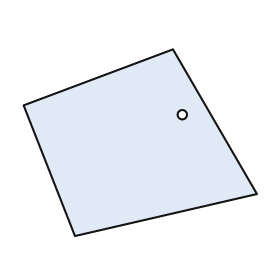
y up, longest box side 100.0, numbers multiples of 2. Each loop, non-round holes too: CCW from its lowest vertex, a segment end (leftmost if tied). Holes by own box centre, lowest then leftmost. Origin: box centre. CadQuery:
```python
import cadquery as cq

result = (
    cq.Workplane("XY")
    .moveTo(-28.0, -40.0)
    .lineTo(50.0, -22.0)
    .lineTo(14.0, 40.0)
    .lineTo(-50.0, 16.0)
    .close()
    .moveTo(18.0, 12.0)
    .circle(2.0)
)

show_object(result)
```